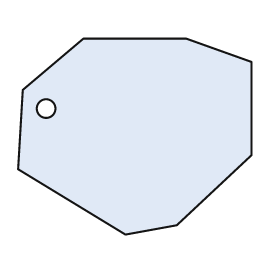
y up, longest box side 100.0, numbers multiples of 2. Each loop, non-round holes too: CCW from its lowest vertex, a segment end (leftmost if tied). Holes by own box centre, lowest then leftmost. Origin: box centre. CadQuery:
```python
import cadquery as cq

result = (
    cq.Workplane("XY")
    .moveTo(-4.0, -42.0)
    .lineTo(18.0, -38.0)
    .lineTo(50.0, -8.0)
    .lineTo(50.0, 32.0)
    .lineTo(22.0, 42.0)
    .lineTo(-22.0, 42.0)
    .lineTo(-48.0, 20.0)
    .lineTo(-50.0, -14.0)
    .close()
    .moveTo(-38.0, 12.0)
    .circle(4.0)
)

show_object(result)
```